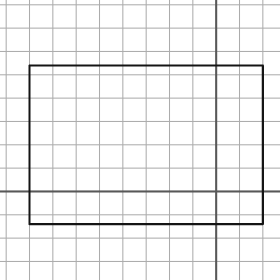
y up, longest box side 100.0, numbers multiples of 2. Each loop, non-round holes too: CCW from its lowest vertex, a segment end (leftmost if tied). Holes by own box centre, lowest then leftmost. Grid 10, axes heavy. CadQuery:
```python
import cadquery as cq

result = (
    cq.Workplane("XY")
    .moveTo(-80.0, -14.0)
    .lineTo(20.0, -14.0)
    .lineTo(20.0, 54.0)
    .lineTo(-80.0, 54.0)
    .close()
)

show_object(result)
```